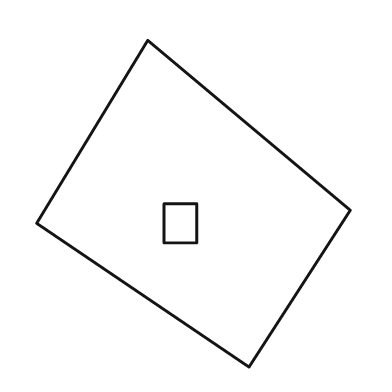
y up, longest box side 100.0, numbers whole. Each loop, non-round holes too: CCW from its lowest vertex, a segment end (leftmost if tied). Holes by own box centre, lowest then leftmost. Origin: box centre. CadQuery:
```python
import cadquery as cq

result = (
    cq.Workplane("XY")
    .moveTo(17.0, -50.0)
    .lineTo(48.0, -2.0)
    .lineTo(-14.0, 50.0)
    .lineTo(-48.0, -6.0)
    .close()
    .moveTo(-9.0, -12.0)
    .lineTo(1.0, -12.0)
    .lineTo(1.0, 0.0)
    .lineTo(-9.0, 0.0)
    .close()
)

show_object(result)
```